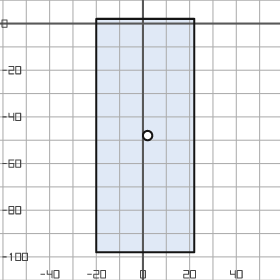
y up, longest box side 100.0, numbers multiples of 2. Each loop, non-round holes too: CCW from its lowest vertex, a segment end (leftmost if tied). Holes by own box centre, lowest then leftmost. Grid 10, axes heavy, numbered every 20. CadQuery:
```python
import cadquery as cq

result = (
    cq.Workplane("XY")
    .moveTo(-20.0, -98.0)
    .lineTo(22.0, -98.0)
    .lineTo(22.0, 2.0)
    .lineTo(-20.0, 2.0)
    .close()
    .moveTo(2.0, -48.0)
    .circle(2.0)
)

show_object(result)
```